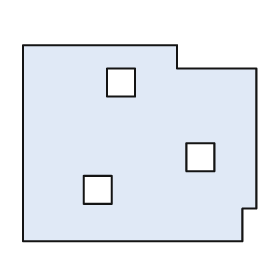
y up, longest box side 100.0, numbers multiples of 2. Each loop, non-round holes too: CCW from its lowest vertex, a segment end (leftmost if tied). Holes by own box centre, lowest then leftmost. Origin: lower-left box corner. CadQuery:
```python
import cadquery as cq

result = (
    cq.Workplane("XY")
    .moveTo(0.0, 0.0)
    .lineTo(94.0, 0.0)
    .lineTo(94.0, 14.0)
    .lineTo(100.0, 14.0)
    .lineTo(100.0, 74.0)
    .lineTo(66.0, 74.0)
    .lineTo(66.0, 84.0)
    .lineTo(0.0, 84.0)
    .close()
    .moveTo(26.0, 16.0)
    .lineTo(38.0, 16.0)
    .lineTo(38.0, 28.0)
    .lineTo(26.0, 28.0)
    .close()
    .moveTo(70.0, 30.0)
    .lineTo(82.0, 30.0)
    .lineTo(82.0, 42.0)
    .lineTo(70.0, 42.0)
    .close()
    .moveTo(36.0, 62.0)
    .lineTo(48.0, 62.0)
    .lineTo(48.0, 74.0)
    .lineTo(36.0, 74.0)
    .close()
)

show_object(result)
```